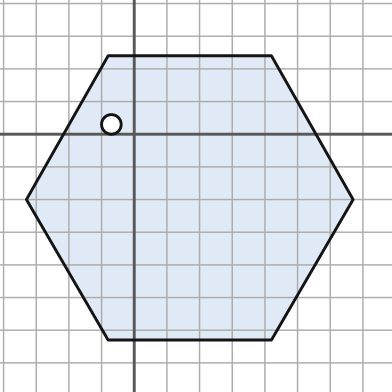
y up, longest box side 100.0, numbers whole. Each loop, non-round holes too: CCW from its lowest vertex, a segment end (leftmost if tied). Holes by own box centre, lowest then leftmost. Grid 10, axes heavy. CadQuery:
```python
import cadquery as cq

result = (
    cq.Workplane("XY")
    .moveTo(-8.0, -63.0)
    .lineTo(42.0, -63.0)
    .lineTo(67.0, -20.0)
    .lineTo(42.0, 24.0)
    .lineTo(-8.0, 24.0)
    .lineTo(-33.0, -20.0)
    .close()
    .moveTo(-7.0, 3.0)
    .circle(3.0)
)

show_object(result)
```